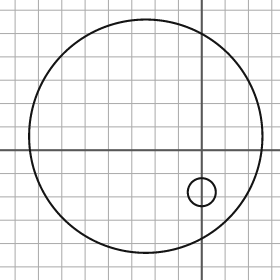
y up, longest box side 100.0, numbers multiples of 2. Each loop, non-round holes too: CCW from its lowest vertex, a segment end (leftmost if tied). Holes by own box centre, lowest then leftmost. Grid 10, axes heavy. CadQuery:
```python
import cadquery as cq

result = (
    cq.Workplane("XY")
    .moveTo(-24.0, 6.0)
    .circle(50.0)
    .moveTo(0.0, -18.0)
    .circle(6.0)
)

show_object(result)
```